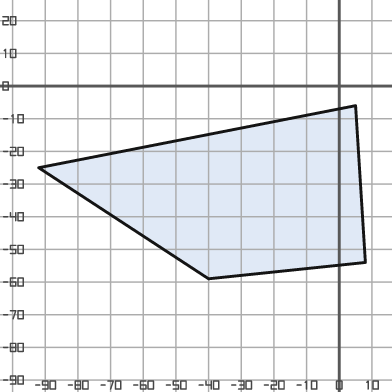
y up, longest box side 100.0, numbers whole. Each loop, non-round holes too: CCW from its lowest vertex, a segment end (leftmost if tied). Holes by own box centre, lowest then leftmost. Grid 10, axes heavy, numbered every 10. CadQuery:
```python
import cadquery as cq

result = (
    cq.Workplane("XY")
    .moveTo(-40.0, -59.0)
    .lineTo(8.0, -54.0)
    .lineTo(5.0, -6.0)
    .lineTo(-92.0, -25.0)
    .close()
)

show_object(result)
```